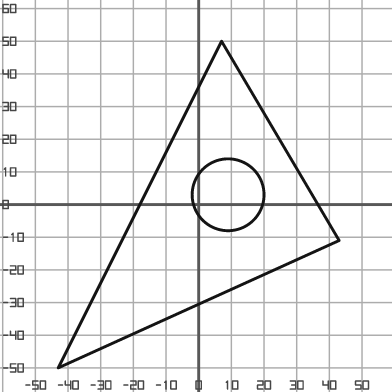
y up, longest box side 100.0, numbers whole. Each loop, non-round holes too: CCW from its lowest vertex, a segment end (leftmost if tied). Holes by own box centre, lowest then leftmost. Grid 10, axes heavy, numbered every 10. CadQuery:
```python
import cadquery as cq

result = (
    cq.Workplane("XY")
    .moveTo(-43.0, -50.0)
    .lineTo(43.0, -11.0)
    .lineTo(7.0, 50.0)
    .close()
    .moveTo(9.0, 3.0)
    .circle(11.0)
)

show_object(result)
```